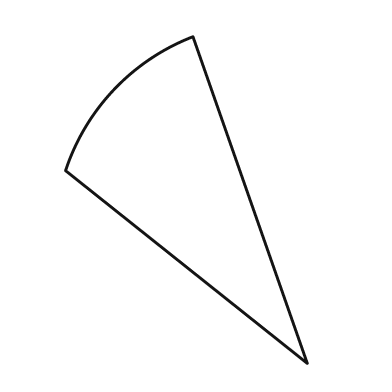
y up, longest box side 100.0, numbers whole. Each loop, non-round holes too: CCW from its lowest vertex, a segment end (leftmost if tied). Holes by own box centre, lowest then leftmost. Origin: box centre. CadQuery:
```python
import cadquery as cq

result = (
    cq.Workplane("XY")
    .moveTo(37.0, -50.0)
    .lineTo(2.0, 50.0)
    .threePointArc((-22.0, 34.0), (-37.0, 9.0))
    .close()
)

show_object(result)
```